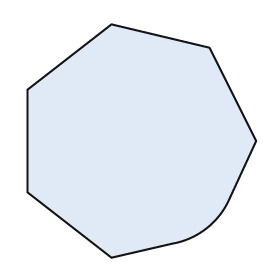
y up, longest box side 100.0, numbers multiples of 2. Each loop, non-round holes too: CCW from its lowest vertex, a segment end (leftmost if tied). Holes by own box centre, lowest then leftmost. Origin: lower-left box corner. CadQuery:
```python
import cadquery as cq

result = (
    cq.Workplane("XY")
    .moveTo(36.0, 0.0)
    .lineTo(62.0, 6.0)
    .threePointArc((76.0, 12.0), (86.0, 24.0))
    .lineTo(98.0, 50.0)
    .lineTo(78.0, 90.0)
    .lineTo(36.0, 100.0)
    .lineTo(0.0, 72.0)
    .lineTo(0.0, 28.0)
    .close()
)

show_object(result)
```